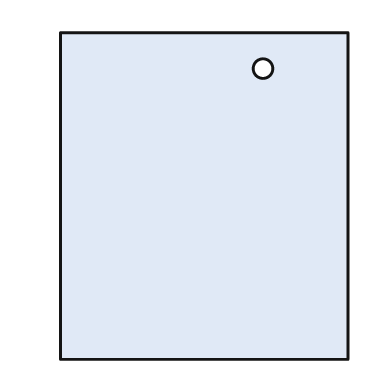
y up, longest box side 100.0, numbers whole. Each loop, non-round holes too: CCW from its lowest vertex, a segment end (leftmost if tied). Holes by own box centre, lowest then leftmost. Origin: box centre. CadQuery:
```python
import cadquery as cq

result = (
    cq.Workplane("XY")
    .moveTo(-44.0, -50.0)
    .lineTo(44.0, -50.0)
    .lineTo(44.0, 50.0)
    .lineTo(-44.0, 50.0)
    .close()
    .moveTo(18.0, 39.0)
    .circle(3.0)
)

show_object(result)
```